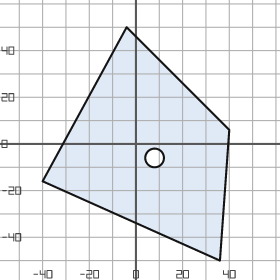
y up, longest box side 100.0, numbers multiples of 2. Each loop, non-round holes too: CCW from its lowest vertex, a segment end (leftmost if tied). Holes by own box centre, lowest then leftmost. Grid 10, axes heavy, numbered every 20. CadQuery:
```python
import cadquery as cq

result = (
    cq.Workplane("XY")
    .moveTo(36.0, -50.0)
    .lineTo(40.0, 6.0)
    .lineTo(-4.0, 50.0)
    .lineTo(-40.0, -16.0)
    .close()
    .moveTo(8.0, -6.0)
    .circle(4.0)
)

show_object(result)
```